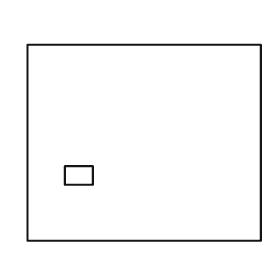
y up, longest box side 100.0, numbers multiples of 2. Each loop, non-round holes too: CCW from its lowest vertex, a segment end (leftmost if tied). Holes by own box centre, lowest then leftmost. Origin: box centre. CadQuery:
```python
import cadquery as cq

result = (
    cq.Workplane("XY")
    .moveTo(-50.0, -42.0)
    .lineTo(50.0, -42.0)
    .lineTo(50.0, 42.0)
    .lineTo(-50.0, 42.0)
    .close()
    .moveTo(-34.0, -18.0)
    .lineTo(-22.0, -18.0)
    .lineTo(-22.0, -10.0)
    .lineTo(-34.0, -10.0)
    .close()
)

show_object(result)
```